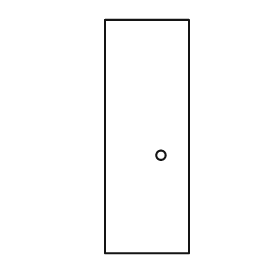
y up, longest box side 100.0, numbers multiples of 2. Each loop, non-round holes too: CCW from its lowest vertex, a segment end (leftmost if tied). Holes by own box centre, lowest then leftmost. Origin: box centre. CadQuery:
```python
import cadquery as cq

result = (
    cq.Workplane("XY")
    .moveTo(-18.0, -50.0)
    .lineTo(18.0, -50.0)
    .lineTo(18.0, 50.0)
    .lineTo(-18.0, 50.0)
    .close()
    .moveTo(6.0, -8.0)
    .circle(2.0)
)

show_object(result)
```